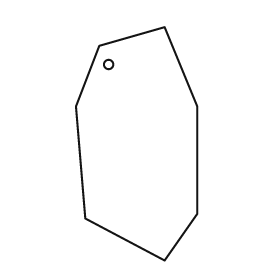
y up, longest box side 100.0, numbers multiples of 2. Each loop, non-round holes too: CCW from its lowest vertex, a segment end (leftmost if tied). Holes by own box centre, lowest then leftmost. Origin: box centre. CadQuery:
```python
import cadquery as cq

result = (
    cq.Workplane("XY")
    .moveTo(12.0, -50.0)
    .lineTo(26.0, -30.0)
    .lineTo(26.0, 16.0)
    .lineTo(12.0, 50.0)
    .lineTo(-16.0, 42.0)
    .lineTo(-26.0, 16.0)
    .lineTo(-22.0, -32.0)
    .close()
    .moveTo(-12.0, 34.0)
    .circle(2.0)
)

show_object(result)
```